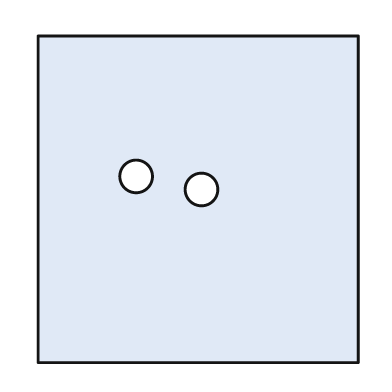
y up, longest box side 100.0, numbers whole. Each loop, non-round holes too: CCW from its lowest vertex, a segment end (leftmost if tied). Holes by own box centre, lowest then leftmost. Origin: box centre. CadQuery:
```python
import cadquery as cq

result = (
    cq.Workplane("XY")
    .moveTo(-49.0, -50.0)
    .lineTo(49.0, -50.0)
    .lineTo(49.0, 50.0)
    .lineTo(-49.0, 50.0)
    .close()
    .moveTo(1.0, 3.0)
    .circle(5.0)
    .moveTo(-19.0, 7.0)
    .circle(5.0)
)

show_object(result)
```